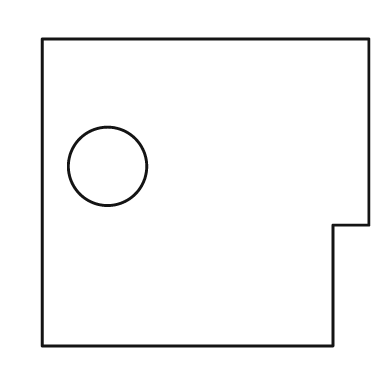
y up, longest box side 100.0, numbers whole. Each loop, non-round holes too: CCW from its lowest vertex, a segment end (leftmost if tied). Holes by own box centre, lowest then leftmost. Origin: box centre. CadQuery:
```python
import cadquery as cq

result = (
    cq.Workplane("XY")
    .moveTo(-50.0, -47.0)
    .lineTo(39.0, -47.0)
    .lineTo(39.0, -10.0)
    .lineTo(50.0, -10.0)
    .lineTo(50.0, 47.0)
    .lineTo(-50.0, 47.0)
    .close()
    .moveTo(-30.0, 8.0)
    .circle(12.0)
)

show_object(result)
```